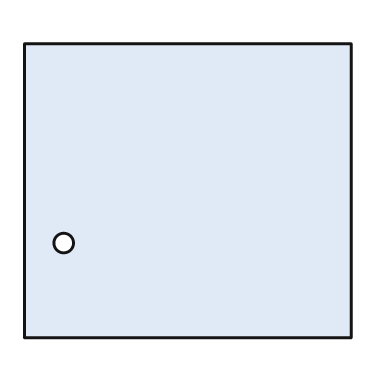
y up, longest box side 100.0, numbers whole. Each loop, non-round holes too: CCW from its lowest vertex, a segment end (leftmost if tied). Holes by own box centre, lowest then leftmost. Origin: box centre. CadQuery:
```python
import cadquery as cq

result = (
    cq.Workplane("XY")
    .moveTo(-50.0, -45.0)
    .lineTo(50.0, -45.0)
    .lineTo(50.0, 45.0)
    .lineTo(-50.0, 45.0)
    .close()
    .moveTo(-38.0, -16.0)
    .circle(3.0)
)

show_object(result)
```